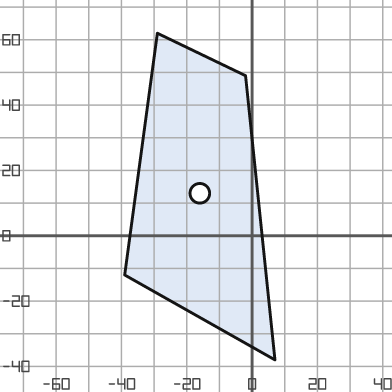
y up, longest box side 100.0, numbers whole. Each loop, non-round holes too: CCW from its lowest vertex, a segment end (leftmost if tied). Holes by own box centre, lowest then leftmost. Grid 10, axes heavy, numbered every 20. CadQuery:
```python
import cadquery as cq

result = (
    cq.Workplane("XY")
    .moveTo(7.0, -38.0)
    .lineTo(-2.0, 49.0)
    .lineTo(-29.0, 62.0)
    .lineTo(-39.0, -12.0)
    .close()
    .moveTo(-16.0, 13.0)
    .circle(3.0)
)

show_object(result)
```